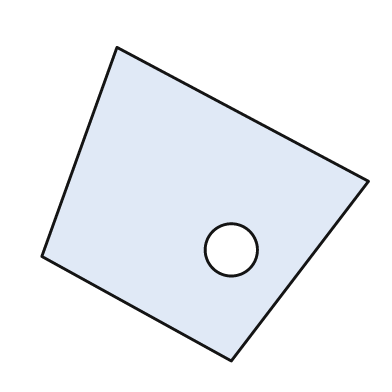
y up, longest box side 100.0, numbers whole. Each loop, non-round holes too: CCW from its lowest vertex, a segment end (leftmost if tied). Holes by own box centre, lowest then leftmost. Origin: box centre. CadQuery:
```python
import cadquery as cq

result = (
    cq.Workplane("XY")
    .moveTo(8.0, -48.0)
    .lineTo(50.0, 7.0)
    .lineTo(-27.0, 48.0)
    .lineTo(-50.0, -16.0)
    .close()
    .moveTo(8.0, -14.0)
    .circle(8.0)
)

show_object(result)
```